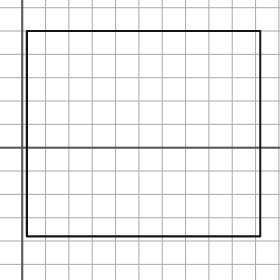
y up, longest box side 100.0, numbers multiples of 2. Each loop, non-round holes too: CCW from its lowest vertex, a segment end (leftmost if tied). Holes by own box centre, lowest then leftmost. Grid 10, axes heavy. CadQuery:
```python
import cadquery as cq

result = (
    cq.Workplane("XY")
    .moveTo(2.0, -38.0)
    .lineTo(102.0, -38.0)
    .lineTo(102.0, 50.0)
    .lineTo(2.0, 50.0)
    .close()
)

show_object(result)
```